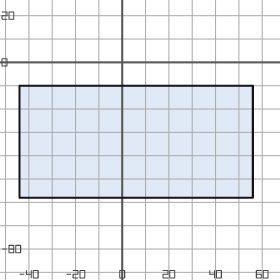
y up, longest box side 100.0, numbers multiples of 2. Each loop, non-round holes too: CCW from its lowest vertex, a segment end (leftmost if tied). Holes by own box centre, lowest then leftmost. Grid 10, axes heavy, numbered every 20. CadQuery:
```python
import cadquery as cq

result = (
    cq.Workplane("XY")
    .moveTo(-44.0, -58.0)
    .lineTo(56.0, -58.0)
    .lineTo(56.0, -10.0)
    .lineTo(-44.0, -10.0)
    .close()
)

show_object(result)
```